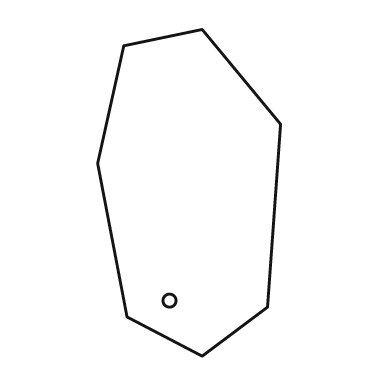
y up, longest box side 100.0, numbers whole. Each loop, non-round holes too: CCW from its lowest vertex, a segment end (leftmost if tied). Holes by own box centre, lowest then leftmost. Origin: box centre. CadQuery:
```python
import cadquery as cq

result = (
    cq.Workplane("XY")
    .moveTo(4.0, -50.0)
    .lineTo(24.0, -35.0)
    .lineTo(28.0, 21.0)
    .lineTo(4.0, 50.0)
    .lineTo(-20.0, 45.0)
    .lineTo(-28.0, 9.0)
    .lineTo(-19.0, -38.0)
    .close()
    .moveTo(-6.0, -33.0)
    .circle(2.0)
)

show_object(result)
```